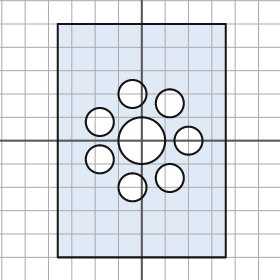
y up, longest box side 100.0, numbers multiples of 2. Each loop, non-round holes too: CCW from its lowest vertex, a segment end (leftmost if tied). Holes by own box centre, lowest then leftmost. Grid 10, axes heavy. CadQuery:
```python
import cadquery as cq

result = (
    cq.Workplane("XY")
    .moveTo(-36.0, -50.0)
    .lineTo(36.0, -50.0)
    .lineTo(36.0, 50.0)
    .lineTo(-36.0, 50.0)
    .close()
    .moveTo(-4.0, -20.0)
    .circle(6.0)
    .moveTo(12.0, -16.0)
    .circle(6.0)
    .moveTo(-18.0, -8.0)
    .circle(6.0)
    .moveTo(0.0, 0.0)
    .circle(10.0)
    .moveTo(20.0, 0.0)
    .circle(6.0)
    .moveTo(-18.0, 8.0)
    .circle(6.0)
    .moveTo(12.0, 16.0)
    .circle(6.0)
    .moveTo(-4.0, 20.0)
    .circle(6.0)
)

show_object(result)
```